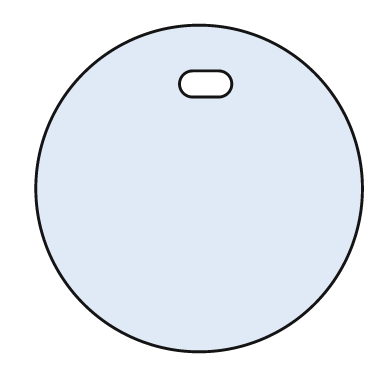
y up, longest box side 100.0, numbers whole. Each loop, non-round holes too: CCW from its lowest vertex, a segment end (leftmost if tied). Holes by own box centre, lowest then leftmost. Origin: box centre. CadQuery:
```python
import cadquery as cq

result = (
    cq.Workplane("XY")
    .moveTo(0.0, 0.0)
    .circle(50.0)
    .moveTo(-2.0, 28.0)
    .lineTo(6.0, 28.0)
    .threePointArc((10.0, 32.0), (6.0, 36.0))
    .lineTo(-2.0, 36.0)
    .threePointArc((-6.0, 32.0), (-2.0, 28.0))
    .close()
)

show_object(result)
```